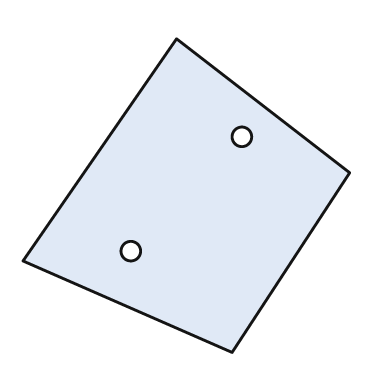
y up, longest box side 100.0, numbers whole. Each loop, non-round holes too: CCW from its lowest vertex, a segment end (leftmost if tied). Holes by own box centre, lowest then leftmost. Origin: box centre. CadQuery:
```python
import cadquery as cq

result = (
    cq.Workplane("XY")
    .moveTo(14.0, -48.0)
    .lineTo(50.0, 7.0)
    .lineTo(-3.0, 48.0)
    .lineTo(-50.0, -20.0)
    .close()
    .moveTo(-17.0, -17.0)
    .circle(3.0)
    .moveTo(17.0, 18.0)
    .circle(3.0)
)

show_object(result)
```